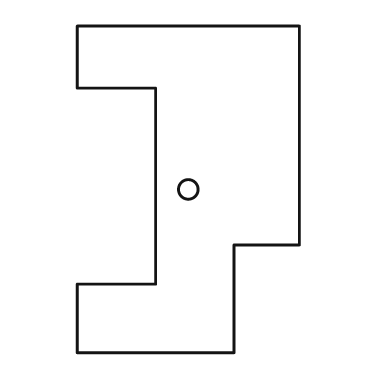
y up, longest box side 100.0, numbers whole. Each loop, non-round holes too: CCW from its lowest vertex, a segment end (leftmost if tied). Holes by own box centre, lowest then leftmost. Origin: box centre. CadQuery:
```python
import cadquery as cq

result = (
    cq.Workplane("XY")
    .moveTo(-34.0, -50.0)
    .lineTo(14.0, -50.0)
    .lineTo(14.0, -17.0)
    .lineTo(34.0, -17.0)
    .lineTo(34.0, 50.0)
    .lineTo(-34.0, 50.0)
    .lineTo(-34.0, 31.0)
    .lineTo(-10.0, 31.0)
    .lineTo(-10.0, -29.0)
    .lineTo(-34.0, -29.0)
    .close()
    .moveTo(0.0, 0.0)
    .circle(3.0)
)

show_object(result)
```